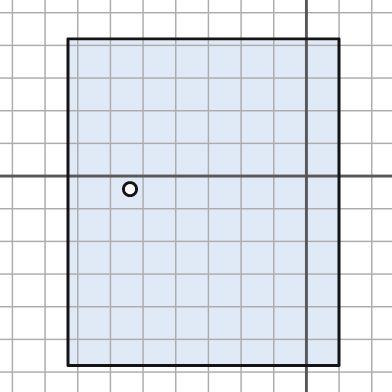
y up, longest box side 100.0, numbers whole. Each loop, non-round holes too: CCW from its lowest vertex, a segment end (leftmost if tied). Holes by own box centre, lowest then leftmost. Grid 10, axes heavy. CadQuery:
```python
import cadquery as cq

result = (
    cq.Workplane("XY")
    .moveTo(-73.0, -58.0)
    .lineTo(10.0, -58.0)
    .lineTo(10.0, 42.0)
    .lineTo(-73.0, 42.0)
    .close()
    .moveTo(-54.0, -4.0)
    .circle(2.0)
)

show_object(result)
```